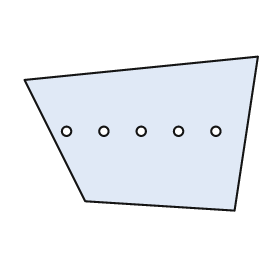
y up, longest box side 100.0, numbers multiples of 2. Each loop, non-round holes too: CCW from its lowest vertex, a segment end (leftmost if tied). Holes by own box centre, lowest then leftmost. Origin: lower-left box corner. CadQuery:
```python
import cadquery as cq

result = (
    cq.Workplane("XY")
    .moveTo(90.0, 0.0)
    .lineTo(100.0, 66.0)
    .lineTo(0.0, 56.0)
    .lineTo(26.0, 4.0)
    .close()
    .moveTo(18.0, 34.0)
    .circle(2.0)
    .moveTo(34.0, 34.0)
    .circle(2.0)
    .moveTo(50.0, 34.0)
    .circle(2.0)
    .moveTo(66.0, 34.0)
    .circle(2.0)
    .moveTo(82.0, 34.0)
    .circle(2.0)
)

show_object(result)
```